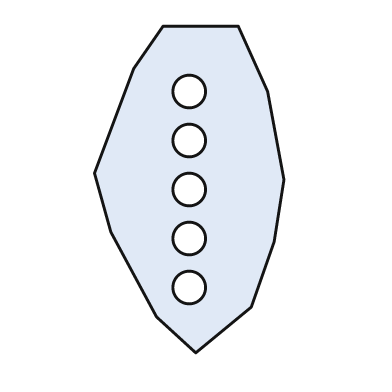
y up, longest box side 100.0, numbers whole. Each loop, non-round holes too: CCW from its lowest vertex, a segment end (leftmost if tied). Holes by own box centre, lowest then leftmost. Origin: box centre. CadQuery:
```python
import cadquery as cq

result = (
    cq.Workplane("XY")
    .moveTo(2.0, -50.0)
    .lineTo(19.0, -36.0)
    .lineTo(26.0, -16.0)
    .lineTo(29.0, 3.0)
    .lineTo(24.0, 30.0)
    .lineTo(15.0, 50.0)
    .lineTo(-8.0, 50.0)
    .lineTo(-17.0, 37.0)
    .lineTo(-29.0, 5.0)
    .lineTo(-24.0, -13.0)
    .lineTo(-10.0, -39.0)
    .close()
    .moveTo(0.0, -30.0)
    .circle(5.0)
    .moveTo(0.0, -15.0)
    .circle(5.0)
    .moveTo(0.0, 0.0)
    .circle(5.0)
    .moveTo(0.0, 15.0)
    .circle(5.0)
    .moveTo(0.0, 30.0)
    .circle(5.0)
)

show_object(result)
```